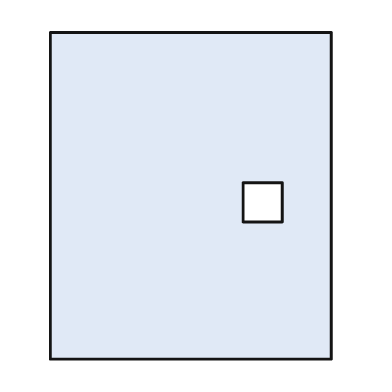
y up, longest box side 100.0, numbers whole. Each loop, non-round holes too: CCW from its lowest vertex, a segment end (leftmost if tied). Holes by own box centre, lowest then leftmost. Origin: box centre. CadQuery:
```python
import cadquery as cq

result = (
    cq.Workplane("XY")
    .moveTo(-43.0, -50.0)
    .lineTo(43.0, -50.0)
    .lineTo(43.0, 50.0)
    .lineTo(-43.0, 50.0)
    .close()
    .moveTo(16.0, -8.0)
    .lineTo(28.0, -8.0)
    .lineTo(28.0, 4.0)
    .lineTo(16.0, 4.0)
    .close()
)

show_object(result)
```